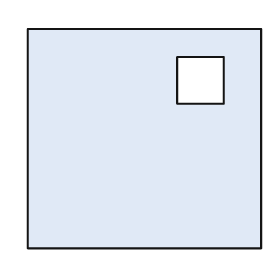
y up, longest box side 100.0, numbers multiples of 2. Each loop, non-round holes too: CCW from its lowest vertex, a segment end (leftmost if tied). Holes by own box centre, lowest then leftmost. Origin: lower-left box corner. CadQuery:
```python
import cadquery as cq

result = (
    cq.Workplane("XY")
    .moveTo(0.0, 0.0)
    .lineTo(100.0, 0.0)
    .lineTo(100.0, 94.0)
    .lineTo(0.0, 94.0)
    .close()
    .moveTo(64.0, 62.0)
    .lineTo(84.0, 62.0)
    .lineTo(84.0, 82.0)
    .lineTo(64.0, 82.0)
    .close()
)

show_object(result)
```